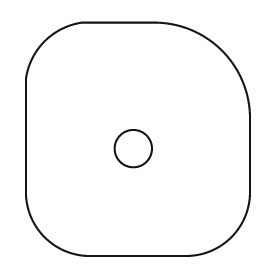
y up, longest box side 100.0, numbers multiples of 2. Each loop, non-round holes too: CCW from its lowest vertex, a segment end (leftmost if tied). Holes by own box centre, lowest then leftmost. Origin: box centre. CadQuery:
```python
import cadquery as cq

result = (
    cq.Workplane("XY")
    .moveTo(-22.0, -50.0)
    .lineTo(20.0, -50.0)
    .threePointArc((40.0, -42.0), (48.0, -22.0))
    .lineTo(48.0, 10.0)
    .threePointArc((36.0, 38.0), (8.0, 50.0))
    .lineTo(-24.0, 50.0)
    .threePointArc((-40.0, 42.0), (-48.0, 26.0))
    .lineTo(-48.0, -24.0)
    .threePointArc((-40.0, -42.0), (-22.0, -50.0))
    .close()
    .moveTo(-2.0, -4.0)
    .circle(8.0)
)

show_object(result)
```